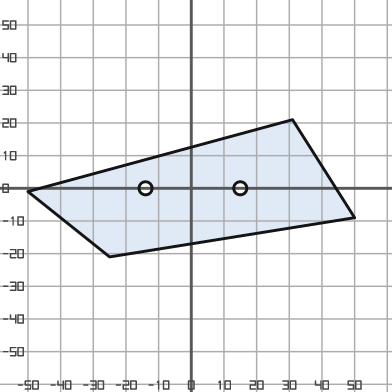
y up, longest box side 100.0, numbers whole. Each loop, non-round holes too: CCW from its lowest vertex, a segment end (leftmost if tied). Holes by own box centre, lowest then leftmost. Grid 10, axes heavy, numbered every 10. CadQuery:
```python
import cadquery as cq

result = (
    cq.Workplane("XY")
    .moveTo(-25.0, -21.0)
    .lineTo(50.0, -9.0)
    .lineTo(31.0, 21.0)
    .lineTo(-50.0, -1.0)
    .close()
    .moveTo(-14.0, 0.0)
    .circle(2.0)
    .moveTo(15.0, 0.0)
    .circle(2.0)
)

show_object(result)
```